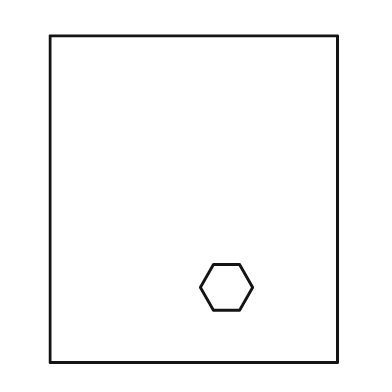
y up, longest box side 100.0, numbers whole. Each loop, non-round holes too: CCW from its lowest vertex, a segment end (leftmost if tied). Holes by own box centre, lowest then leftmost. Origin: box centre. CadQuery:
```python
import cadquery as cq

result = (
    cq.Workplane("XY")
    .moveTo(-44.0, -50.0)
    .lineTo(44.0, -50.0)
    .lineTo(44.0, 50.0)
    .lineTo(-44.0, 50.0)
    .close()
    .moveTo(6.0, -34.0)
    .lineTo(14.0, -34.0)
    .lineTo(18.0, -27.0)
    .lineTo(14.0, -20.0)
    .lineTo(6.0, -20.0)
    .lineTo(2.0, -27.0)
    .close()
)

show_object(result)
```